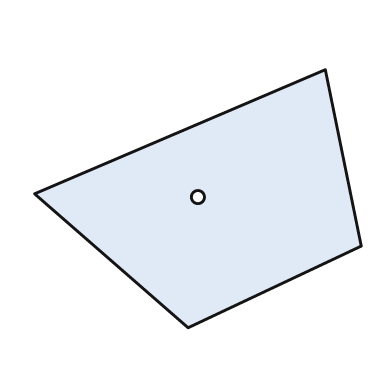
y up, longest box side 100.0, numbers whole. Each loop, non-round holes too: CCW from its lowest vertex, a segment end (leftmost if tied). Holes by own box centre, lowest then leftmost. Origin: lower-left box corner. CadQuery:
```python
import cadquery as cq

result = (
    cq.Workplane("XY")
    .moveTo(47.0, 0.0)
    .lineTo(100.0, 25.0)
    .lineTo(89.0, 79.0)
    .lineTo(0.0, 41.0)
    .close()
    .moveTo(50.0, 40.0)
    .circle(2.0)
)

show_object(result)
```